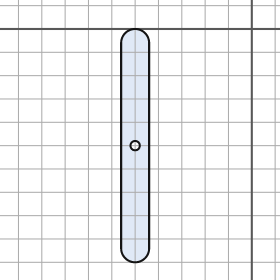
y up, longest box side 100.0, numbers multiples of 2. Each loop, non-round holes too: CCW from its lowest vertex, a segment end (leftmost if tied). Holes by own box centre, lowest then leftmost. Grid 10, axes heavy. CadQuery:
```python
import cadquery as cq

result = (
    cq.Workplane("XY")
    .moveTo(-56.0, -94.0)
    .threePointArc((-50.0, -100.0), (-44.0, -94.0))
    .lineTo(-44.0, -6.0)
    .threePointArc((-50.0, 0.0), (-56.0, -6.0))
    .close()
    .moveTo(-50.0, -50.0)
    .circle(2.0)
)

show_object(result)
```